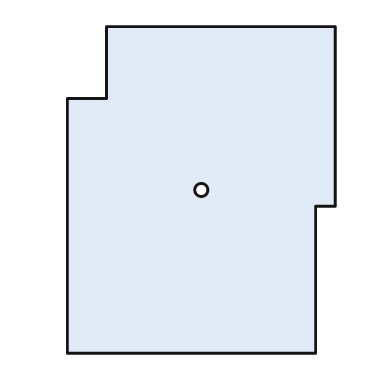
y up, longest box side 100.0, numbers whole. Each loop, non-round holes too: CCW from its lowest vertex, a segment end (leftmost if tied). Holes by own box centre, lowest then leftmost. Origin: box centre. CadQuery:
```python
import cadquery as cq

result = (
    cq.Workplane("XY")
    .moveTo(-41.0, -50.0)
    .lineTo(35.0, -50.0)
    .lineTo(35.0, -5.0)
    .lineTo(41.0, -5.0)
    .lineTo(41.0, 50.0)
    .lineTo(-29.0, 50.0)
    .lineTo(-29.0, 28.0)
    .lineTo(-41.0, 28.0)
    .close()
    .moveTo(0.0, 0.0)
    .circle(2.0)
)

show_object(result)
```